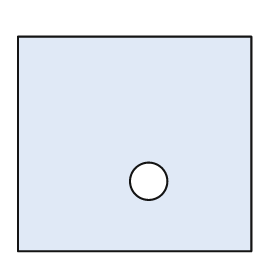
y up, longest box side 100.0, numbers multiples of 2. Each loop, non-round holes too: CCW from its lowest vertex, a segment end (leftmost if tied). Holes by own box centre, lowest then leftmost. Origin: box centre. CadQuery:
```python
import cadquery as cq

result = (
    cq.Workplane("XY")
    .moveTo(-50.0, -46.0)
    .lineTo(50.0, -46.0)
    .lineTo(50.0, 46.0)
    .lineTo(-50.0, 46.0)
    .close()
    .moveTo(6.0, -16.0)
    .circle(8.0)
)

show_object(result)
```